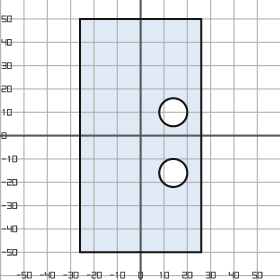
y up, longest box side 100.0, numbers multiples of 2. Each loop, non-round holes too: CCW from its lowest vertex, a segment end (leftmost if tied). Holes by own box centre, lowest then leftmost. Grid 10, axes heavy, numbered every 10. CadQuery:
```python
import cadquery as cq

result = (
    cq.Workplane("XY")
    .moveTo(-26.0, -50.0)
    .lineTo(26.0, -50.0)
    .lineTo(26.0, 50.0)
    .lineTo(-26.0, 50.0)
    .close()
    .moveTo(14.0, -16.0)
    .circle(6.0)
    .moveTo(14.0, 10.0)
    .circle(6.0)
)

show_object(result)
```